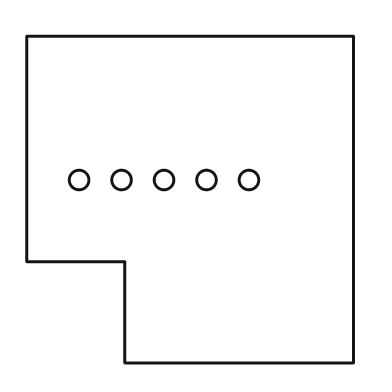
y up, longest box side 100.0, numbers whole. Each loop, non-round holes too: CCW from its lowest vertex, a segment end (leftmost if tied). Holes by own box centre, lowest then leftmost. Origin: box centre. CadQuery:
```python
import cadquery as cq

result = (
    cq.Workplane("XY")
    .moveTo(-20.0, -50.0)
    .lineTo(50.0, -50.0)
    .lineTo(50.0, 50.0)
    .lineTo(-50.0, 50.0)
    .lineTo(-50.0, -19.0)
    .lineTo(-20.0, -19.0)
    .close()
    .moveTo(-34.0, 6.0)
    .circle(3.0)
    .moveTo(-21.0, 6.0)
    .circle(3.0)
    .moveTo(-8.0, 6.0)
    .circle(3.0)
    .moveTo(5.0, 6.0)
    .circle(3.0)
    .moveTo(18.0, 6.0)
    .circle(3.0)
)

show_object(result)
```